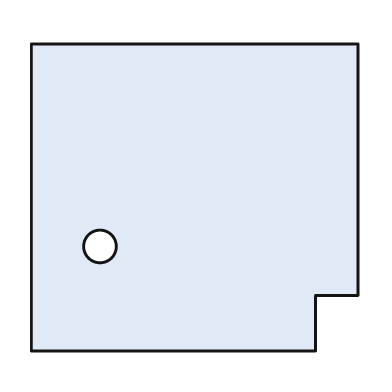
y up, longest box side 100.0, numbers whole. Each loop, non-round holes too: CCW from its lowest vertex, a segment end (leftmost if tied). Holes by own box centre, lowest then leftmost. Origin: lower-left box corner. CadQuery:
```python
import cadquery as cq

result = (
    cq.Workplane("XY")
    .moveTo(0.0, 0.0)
    .lineTo(87.0, 0.0)
    .lineTo(87.0, 17.0)
    .lineTo(100.0, 17.0)
    .lineTo(100.0, 94.0)
    .lineTo(0.0, 94.0)
    .close()
    .moveTo(21.0, 32.0)
    .circle(5.0)
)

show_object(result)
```